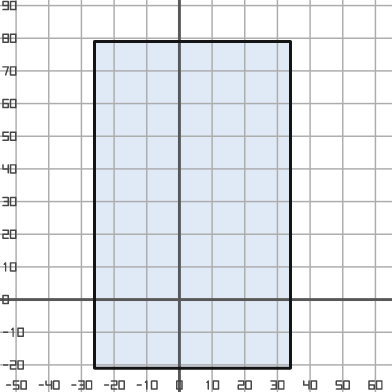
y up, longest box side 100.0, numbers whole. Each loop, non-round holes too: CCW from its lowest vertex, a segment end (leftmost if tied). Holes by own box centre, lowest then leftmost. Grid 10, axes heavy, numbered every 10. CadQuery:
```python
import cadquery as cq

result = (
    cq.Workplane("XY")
    .moveTo(-26.0, -21.0)
    .lineTo(34.0, -21.0)
    .lineTo(34.0, 79.0)
    .lineTo(-26.0, 79.0)
    .close()
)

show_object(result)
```